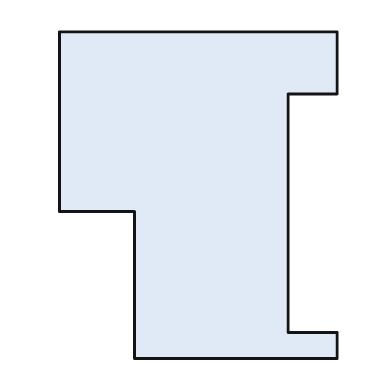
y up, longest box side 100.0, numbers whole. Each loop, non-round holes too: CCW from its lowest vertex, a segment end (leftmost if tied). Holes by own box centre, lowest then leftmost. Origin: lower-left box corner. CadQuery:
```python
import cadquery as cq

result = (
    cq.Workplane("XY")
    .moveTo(23.0, 0.0)
    .lineTo(85.0, 0.0)
    .lineTo(85.0, 8.0)
    .lineTo(70.0, 8.0)
    .lineTo(70.0, 81.0)
    .lineTo(85.0, 81.0)
    .lineTo(85.0, 100.0)
    .lineTo(0.0, 100.0)
    .lineTo(0.0, 45.0)
    .lineTo(23.0, 45.0)
    .close()
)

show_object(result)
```